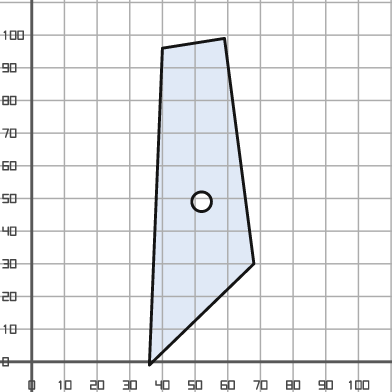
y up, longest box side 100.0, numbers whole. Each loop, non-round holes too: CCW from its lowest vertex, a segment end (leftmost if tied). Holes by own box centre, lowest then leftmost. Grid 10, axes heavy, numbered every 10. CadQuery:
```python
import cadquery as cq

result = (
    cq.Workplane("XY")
    .moveTo(36.0, -1.0)
    .lineTo(68.0, 30.0)
    .lineTo(59.0, 99.0)
    .lineTo(40.0, 96.0)
    .close()
    .moveTo(52.0, 49.0)
    .circle(3.0)
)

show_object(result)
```